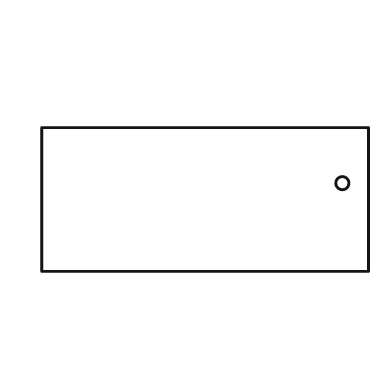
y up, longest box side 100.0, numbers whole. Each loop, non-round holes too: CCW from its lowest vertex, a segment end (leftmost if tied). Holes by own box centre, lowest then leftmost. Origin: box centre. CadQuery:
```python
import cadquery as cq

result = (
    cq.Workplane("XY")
    .moveTo(-50.0, -22.0)
    .lineTo(50.0, -22.0)
    .lineTo(50.0, 22.0)
    .lineTo(-50.0, 22.0)
    .close()
    .moveTo(42.0, 5.0)
    .circle(2.0)
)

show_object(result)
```